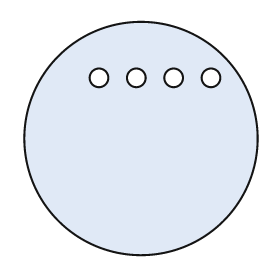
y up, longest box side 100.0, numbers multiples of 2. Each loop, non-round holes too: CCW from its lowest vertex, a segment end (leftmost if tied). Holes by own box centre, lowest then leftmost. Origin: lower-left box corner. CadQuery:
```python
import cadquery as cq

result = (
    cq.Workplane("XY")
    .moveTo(50.0, 50.0)
    .circle(50.0)
    .moveTo(32.0, 76.0)
    .circle(4.0)
    .moveTo(48.0, 76.0)
    .circle(4.0)
    .moveTo(64.0, 76.0)
    .circle(4.0)
    .moveTo(80.0, 76.0)
    .circle(4.0)
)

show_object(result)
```